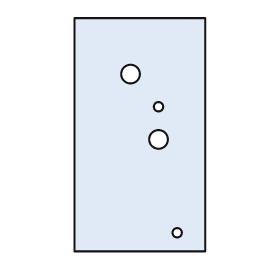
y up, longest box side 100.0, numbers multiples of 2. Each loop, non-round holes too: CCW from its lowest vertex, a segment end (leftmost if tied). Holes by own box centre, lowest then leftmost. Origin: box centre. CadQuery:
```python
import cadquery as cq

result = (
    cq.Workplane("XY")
    .moveTo(-28.0, -50.0)
    .lineTo(28.0, -50.0)
    .lineTo(28.0, 50.0)
    .lineTo(-28.0, 50.0)
    .close()
    .moveTo(16.0, -42.0)
    .circle(2.0)
    .moveTo(8.0, -2.0)
    .circle(4.0)
    .moveTo(8.0, 12.0)
    .circle(2.0)
    .moveTo(-4.0, 26.0)
    .circle(4.0)
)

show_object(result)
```